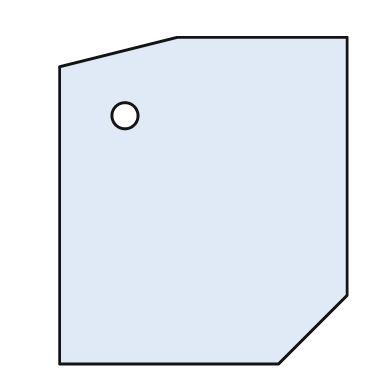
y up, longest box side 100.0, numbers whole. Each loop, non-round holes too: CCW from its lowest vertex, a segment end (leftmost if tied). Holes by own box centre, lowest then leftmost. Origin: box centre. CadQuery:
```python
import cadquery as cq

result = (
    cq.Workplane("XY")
    .moveTo(-44.0, -50.0)
    .lineTo(23.0, -50.0)
    .lineTo(44.0, -29.0)
    .lineTo(44.0, 50.0)
    .lineTo(-8.0, 50.0)
    .lineTo(-44.0, 41.0)
    .close()
    .moveTo(-24.0, 26.0)
    .circle(4.0)
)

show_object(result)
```